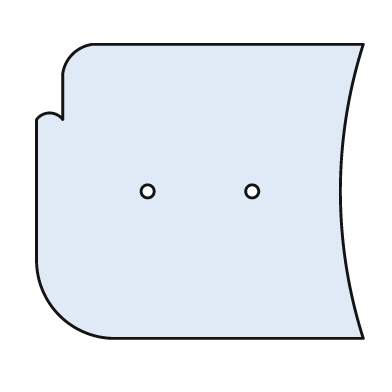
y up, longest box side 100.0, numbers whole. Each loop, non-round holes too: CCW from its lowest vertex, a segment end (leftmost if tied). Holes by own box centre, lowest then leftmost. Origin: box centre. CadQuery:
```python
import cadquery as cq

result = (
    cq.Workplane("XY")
    .moveTo(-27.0, -45.0)
    .lineTo(50.0, -45.0)
    .threePointArc((43.0, 0.0), (50.0, 45.0))
    .lineTo(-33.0, 45.0)
    .threePointArc((-39.0, 42.0), (-42.0, 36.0))
    .lineTo(-42.0, 22.0)
    .threePointArc((-46.0, 24.0), (-50.0, 22.0))
    .lineTo(-50.0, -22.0)
    .threePointArc((-43.0, -38.0), (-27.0, -45.0))
    .close()
    .moveTo(-16.0, 0.0)
    .circle(2.0)
    .moveTo(16.0, 0.0)
    .circle(2.0)
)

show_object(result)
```